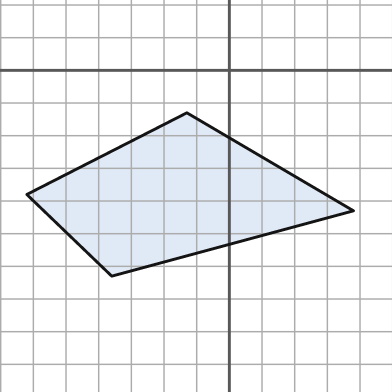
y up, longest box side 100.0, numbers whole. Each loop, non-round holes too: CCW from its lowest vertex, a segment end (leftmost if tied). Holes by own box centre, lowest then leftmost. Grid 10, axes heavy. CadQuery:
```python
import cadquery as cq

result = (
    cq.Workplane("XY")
    .moveTo(-36.0, -63.0)
    .lineTo(38.0, -43.0)
    .lineTo(-13.0, -13.0)
    .lineTo(-62.0, -38.0)
    .close()
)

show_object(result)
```